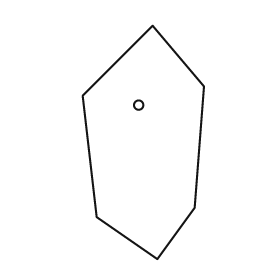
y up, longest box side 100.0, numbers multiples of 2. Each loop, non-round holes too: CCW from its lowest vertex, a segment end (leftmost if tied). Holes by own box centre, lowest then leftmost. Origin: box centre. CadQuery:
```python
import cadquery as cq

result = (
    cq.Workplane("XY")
    .moveTo(6.0, -50.0)
    .lineTo(22.0, -28.0)
    .lineTo(26.0, 24.0)
    .lineTo(4.0, 50.0)
    .lineTo(-26.0, 20.0)
    .lineTo(-20.0, -32.0)
    .close()
    .moveTo(-2.0, 16.0)
    .circle(2.0)
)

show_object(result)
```